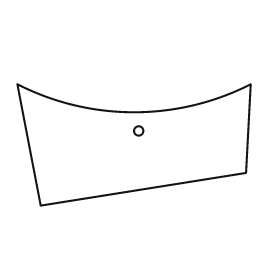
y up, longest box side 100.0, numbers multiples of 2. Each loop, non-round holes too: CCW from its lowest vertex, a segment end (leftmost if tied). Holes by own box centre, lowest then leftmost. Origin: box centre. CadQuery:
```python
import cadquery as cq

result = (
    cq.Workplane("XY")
    .moveTo(-40.0, -26.0)
    .lineTo(48.0, -12.0)
    .lineTo(50.0, 26.0)
    .threePointArc((0.0, 14.0), (-50.0, 26.0))
    .close()
    .moveTo(2.0, 6.0)
    .circle(2.0)
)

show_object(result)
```